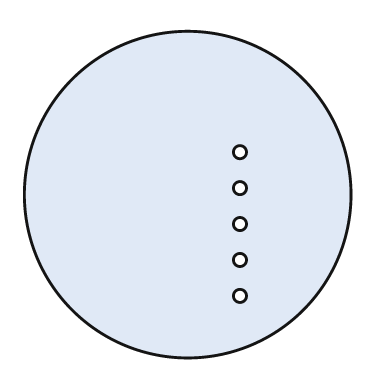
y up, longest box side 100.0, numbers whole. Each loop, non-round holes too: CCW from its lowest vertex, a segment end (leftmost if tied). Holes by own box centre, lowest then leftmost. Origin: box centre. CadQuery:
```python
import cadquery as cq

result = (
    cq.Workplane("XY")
    .moveTo(0.0, 0.0)
    .circle(50.0)
    .moveTo(16.0, -31.0)
    .circle(2.0)
    .moveTo(16.0, -20.0)
    .circle(2.0)
    .moveTo(16.0, -9.0)
    .circle(2.0)
    .moveTo(16.0, 2.0)
    .circle(2.0)
    .moveTo(16.0, 13.0)
    .circle(2.0)
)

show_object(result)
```